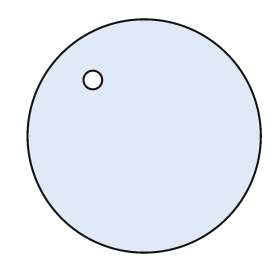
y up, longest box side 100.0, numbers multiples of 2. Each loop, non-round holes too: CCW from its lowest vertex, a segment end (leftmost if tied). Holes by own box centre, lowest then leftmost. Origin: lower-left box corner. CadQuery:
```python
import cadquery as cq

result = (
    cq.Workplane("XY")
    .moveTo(50.0, 50.0)
    .circle(50.0)
    .moveTo(28.0, 74.0)
    .circle(4.0)
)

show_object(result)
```